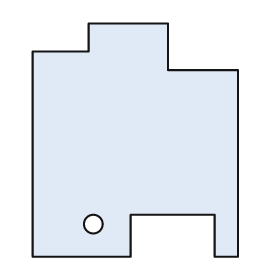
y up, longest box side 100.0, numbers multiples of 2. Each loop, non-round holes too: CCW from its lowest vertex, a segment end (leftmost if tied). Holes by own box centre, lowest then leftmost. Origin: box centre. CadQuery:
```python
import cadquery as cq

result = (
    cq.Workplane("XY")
    .moveTo(-44.0, -50.0)
    .lineTo(-2.0, -50.0)
    .lineTo(-2.0, -32.0)
    .lineTo(34.0, -32.0)
    .lineTo(34.0, -50.0)
    .lineTo(44.0, -50.0)
    .lineTo(44.0, 30.0)
    .lineTo(14.0, 30.0)
    .lineTo(14.0, 50.0)
    .lineTo(-20.0, 50.0)
    .lineTo(-20.0, 38.0)
    .lineTo(-44.0, 38.0)
    .close()
    .moveTo(-18.0, -36.0)
    .circle(4.0)
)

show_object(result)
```